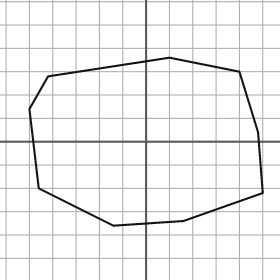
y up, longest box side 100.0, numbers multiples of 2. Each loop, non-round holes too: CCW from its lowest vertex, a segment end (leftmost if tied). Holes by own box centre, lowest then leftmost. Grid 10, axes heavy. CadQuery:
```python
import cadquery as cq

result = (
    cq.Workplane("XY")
    .moveTo(-14.0, -36.0)
    .lineTo(16.0, -34.0)
    .lineTo(50.0, -22.0)
    .lineTo(48.0, 4.0)
    .lineTo(40.0, 30.0)
    .lineTo(10.0, 36.0)
    .lineTo(-42.0, 28.0)
    .lineTo(-50.0, 14.0)
    .lineTo(-46.0, -20.0)
    .close()
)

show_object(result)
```